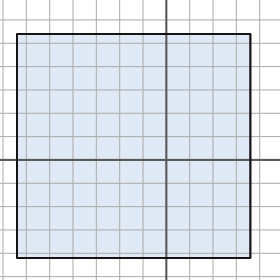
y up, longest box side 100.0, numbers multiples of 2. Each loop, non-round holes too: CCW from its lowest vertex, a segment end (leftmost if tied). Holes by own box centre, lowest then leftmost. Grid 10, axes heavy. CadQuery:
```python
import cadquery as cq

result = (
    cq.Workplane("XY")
    .moveTo(-64.0, -42.0)
    .lineTo(36.0, -42.0)
    .lineTo(36.0, 54.0)
    .lineTo(-64.0, 54.0)
    .close()
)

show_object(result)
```